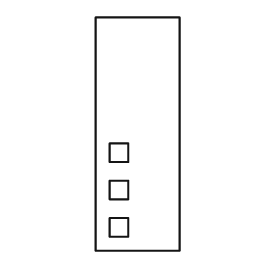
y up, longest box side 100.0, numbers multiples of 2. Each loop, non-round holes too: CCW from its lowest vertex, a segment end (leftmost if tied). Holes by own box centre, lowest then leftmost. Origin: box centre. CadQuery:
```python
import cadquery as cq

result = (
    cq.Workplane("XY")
    .moveTo(-18.0, -50.0)
    .lineTo(18.0, -50.0)
    .lineTo(18.0, 50.0)
    .lineTo(-18.0, 50.0)
    .close()
    .moveTo(-12.0, -44.0)
    .lineTo(-4.0, -44.0)
    .lineTo(-4.0, -36.0)
    .lineTo(-12.0, -36.0)
    .close()
    .moveTo(-12.0, -28.0)
    .lineTo(-4.0, -28.0)
    .lineTo(-4.0, -20.0)
    .lineTo(-12.0, -20.0)
    .close()
    .moveTo(-12.0, -12.0)
    .lineTo(-4.0, -12.0)
    .lineTo(-4.0, -4.0)
    .lineTo(-12.0, -4.0)
    .close()
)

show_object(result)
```